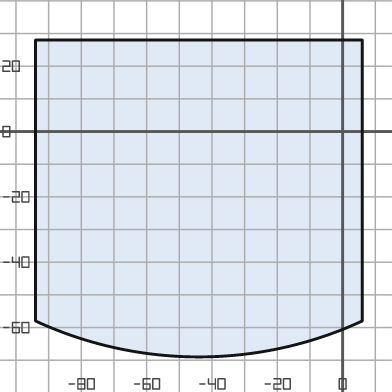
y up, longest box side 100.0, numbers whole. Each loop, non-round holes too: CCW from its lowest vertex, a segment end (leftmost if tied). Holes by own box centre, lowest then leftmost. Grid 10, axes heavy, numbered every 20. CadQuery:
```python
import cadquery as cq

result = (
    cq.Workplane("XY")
    .moveTo(-94.0, -58.0)
    .threePointArc((-44.0, -69.0), (6.0, -58.0))
    .lineTo(6.0, 28.0)
    .lineTo(-94.0, 28.0)
    .close()
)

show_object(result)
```